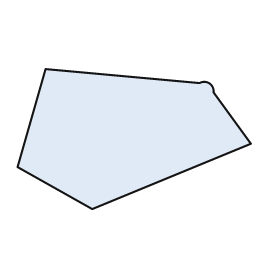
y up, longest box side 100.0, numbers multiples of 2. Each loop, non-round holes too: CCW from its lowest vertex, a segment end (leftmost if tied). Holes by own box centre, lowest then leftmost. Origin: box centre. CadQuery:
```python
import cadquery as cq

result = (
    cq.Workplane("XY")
    .moveTo(-18.0, -30.0)
    .lineTo(50.0, -2.0)
    .lineTo(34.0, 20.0)
    .threePointArc((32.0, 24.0), (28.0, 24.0))
    .lineTo(-38.0, 30.0)
    .lineTo(-50.0, -12.0)
    .close()
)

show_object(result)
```